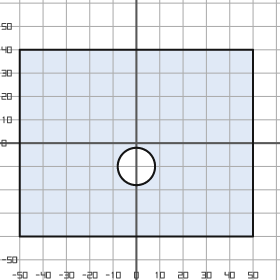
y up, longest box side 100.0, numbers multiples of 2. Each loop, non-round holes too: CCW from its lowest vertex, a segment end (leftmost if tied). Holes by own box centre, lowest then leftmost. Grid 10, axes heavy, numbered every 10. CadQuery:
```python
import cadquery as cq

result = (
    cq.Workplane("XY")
    .moveTo(-50.0, -40.0)
    .lineTo(50.0, -40.0)
    .lineTo(50.0, 40.0)
    .lineTo(-50.0, 40.0)
    .close()
    .moveTo(0.0, -10.0)
    .circle(8.0)
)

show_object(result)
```